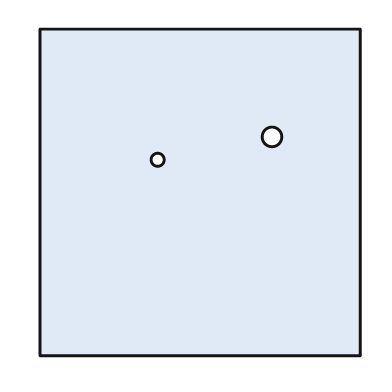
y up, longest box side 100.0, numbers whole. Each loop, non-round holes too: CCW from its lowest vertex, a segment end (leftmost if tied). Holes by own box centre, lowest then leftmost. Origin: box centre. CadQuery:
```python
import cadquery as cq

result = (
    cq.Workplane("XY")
    .moveTo(-49.0, -50.0)
    .lineTo(49.0, -50.0)
    .lineTo(49.0, 50.0)
    .lineTo(-49.0, 50.0)
    .close()
    .moveTo(-13.0, 10.0)
    .circle(2.0)
    .moveTo(22.0, 17.0)
    .circle(3.0)
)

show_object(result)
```